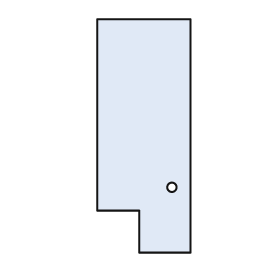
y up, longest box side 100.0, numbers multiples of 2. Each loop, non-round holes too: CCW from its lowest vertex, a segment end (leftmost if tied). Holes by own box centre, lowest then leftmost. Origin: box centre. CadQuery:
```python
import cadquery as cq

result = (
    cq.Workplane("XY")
    .moveTo(-2.0, -50.0)
    .lineTo(20.0, -50.0)
    .lineTo(20.0, 50.0)
    .lineTo(-20.0, 50.0)
    .lineTo(-20.0, -32.0)
    .lineTo(-2.0, -32.0)
    .close()
    .moveTo(12.0, -22.0)
    .circle(2.0)
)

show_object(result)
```